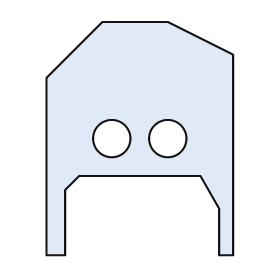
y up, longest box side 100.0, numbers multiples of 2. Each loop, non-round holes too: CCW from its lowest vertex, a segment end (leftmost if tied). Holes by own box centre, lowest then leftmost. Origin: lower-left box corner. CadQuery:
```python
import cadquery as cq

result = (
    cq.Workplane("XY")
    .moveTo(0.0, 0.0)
    .lineTo(8.0, 0.0)
    .lineTo(8.0, 28.0)
    .lineTo(14.0, 34.0)
    .lineTo(66.0, 34.0)
    .lineTo(74.0, 20.0)
    .lineTo(74.0, 0.0)
    .lineTo(80.0, 0.0)
    .lineTo(80.0, 86.0)
    .lineTo(52.0, 100.0)
    .lineTo(24.0, 100.0)
    .lineTo(0.0, 76.0)
    .close()
    .moveTo(28.0, 50.0)
    .circle(8.0)
    .moveTo(52.0, 50.0)
    .circle(8.0)
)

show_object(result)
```